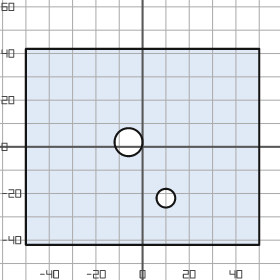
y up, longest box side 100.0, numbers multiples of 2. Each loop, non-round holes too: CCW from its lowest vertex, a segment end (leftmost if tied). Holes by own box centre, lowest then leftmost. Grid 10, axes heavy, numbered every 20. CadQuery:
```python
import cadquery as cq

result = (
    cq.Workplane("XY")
    .moveTo(-50.0, -42.0)
    .lineTo(50.0, -42.0)
    .lineTo(50.0, 42.0)
    .lineTo(-50.0, 42.0)
    .close()
    .moveTo(10.0, -22.0)
    .circle(4.0)
    .moveTo(-6.0, 2.0)
    .circle(6.0)
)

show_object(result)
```